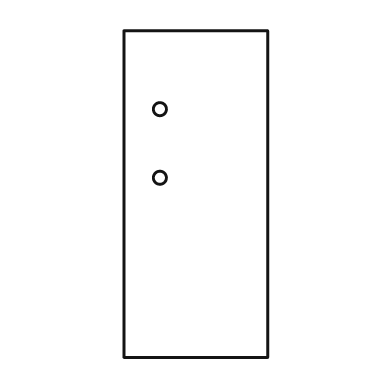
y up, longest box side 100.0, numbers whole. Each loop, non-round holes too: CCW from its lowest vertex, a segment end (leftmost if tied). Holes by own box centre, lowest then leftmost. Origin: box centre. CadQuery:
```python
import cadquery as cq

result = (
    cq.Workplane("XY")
    .moveTo(-22.0, -50.0)
    .lineTo(22.0, -50.0)
    .lineTo(22.0, 50.0)
    .lineTo(-22.0, 50.0)
    .close()
    .moveTo(-11.0, 5.0)
    .circle(2.0)
    .moveTo(-11.0, 26.0)
    .circle(2.0)
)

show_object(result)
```